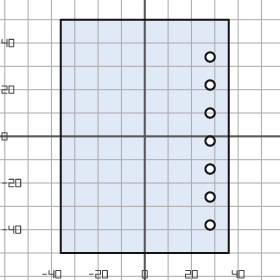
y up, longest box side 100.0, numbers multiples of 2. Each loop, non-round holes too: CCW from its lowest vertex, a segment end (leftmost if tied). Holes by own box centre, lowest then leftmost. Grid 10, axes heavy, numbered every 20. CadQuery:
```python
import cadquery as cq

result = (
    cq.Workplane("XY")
    .moveTo(-36.0, -50.0)
    .lineTo(36.0, -50.0)
    .lineTo(36.0, 50.0)
    .lineTo(-36.0, 50.0)
    .close()
    .moveTo(28.0, -38.0)
    .circle(2.0)
    .moveTo(28.0, -26.0)
    .circle(2.0)
    .moveTo(28.0, -14.0)
    .circle(2.0)
    .moveTo(28.0, -2.0)
    .circle(2.0)
    .moveTo(28.0, 10.0)
    .circle(2.0)
    .moveTo(28.0, 22.0)
    .circle(2.0)
    .moveTo(28.0, 34.0)
    .circle(2.0)
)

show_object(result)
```